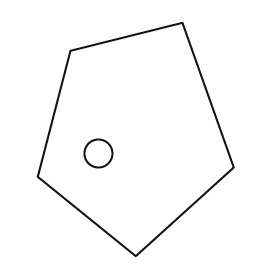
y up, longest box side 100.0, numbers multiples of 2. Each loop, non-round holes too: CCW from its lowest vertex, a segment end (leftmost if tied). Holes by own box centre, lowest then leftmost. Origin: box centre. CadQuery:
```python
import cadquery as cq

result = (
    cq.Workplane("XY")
    .moveTo(0.0, -50.0)
    .lineTo(42.0, -12.0)
    .lineTo(20.0, 50.0)
    .lineTo(-28.0, 38.0)
    .lineTo(-42.0, -16.0)
    .close()
    .moveTo(-16.0, -6.0)
    .circle(6.0)
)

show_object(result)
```